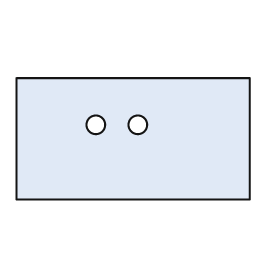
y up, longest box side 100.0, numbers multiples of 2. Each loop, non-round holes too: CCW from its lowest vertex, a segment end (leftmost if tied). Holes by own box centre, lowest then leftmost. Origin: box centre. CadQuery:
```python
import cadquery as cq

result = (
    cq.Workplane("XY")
    .moveTo(-50.0, -26.0)
    .lineTo(50.0, -26.0)
    .lineTo(50.0, 26.0)
    .lineTo(-50.0, 26.0)
    .close()
    .moveTo(-16.0, 6.0)
    .circle(4.0)
    .moveTo(2.0, 6.0)
    .circle(4.0)
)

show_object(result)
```